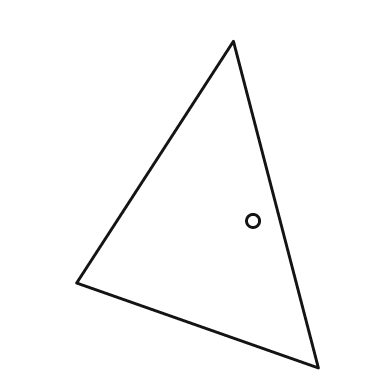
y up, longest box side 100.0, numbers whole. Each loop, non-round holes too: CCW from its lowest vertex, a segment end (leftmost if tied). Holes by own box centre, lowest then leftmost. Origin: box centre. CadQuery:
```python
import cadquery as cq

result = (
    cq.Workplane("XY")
    .moveTo(37.0, -50.0)
    .lineTo(11.0, 50.0)
    .lineTo(-37.0, -24.0)
    .close()
    .moveTo(17.0, -5.0)
    .circle(2.0)
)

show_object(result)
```